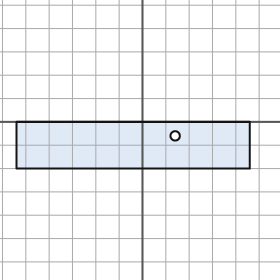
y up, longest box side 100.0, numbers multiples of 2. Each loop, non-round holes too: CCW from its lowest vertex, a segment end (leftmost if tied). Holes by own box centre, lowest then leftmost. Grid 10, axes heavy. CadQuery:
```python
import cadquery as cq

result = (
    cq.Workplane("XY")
    .moveTo(-54.0, -20.0)
    .lineTo(46.0, -20.0)
    .lineTo(46.0, 0.0)
    .lineTo(-54.0, 0.0)
    .close()
    .moveTo(14.0, -6.0)
    .circle(2.0)
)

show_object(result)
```